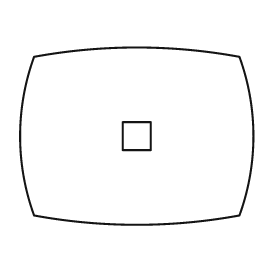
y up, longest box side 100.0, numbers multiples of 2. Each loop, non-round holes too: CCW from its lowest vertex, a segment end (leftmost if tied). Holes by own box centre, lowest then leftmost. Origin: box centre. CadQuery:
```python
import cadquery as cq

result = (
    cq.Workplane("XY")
    .moveTo(-44.0, -34.0)
    .threePointArc((0.0, -38.0), (44.0, -34.0))
    .threePointArc((50.0, 0.0), (44.0, 34.0))
    .threePointArc((0.0, 38.0), (-44.0, 34.0))
    .threePointArc((-50.0, 0.0), (-44.0, -34.0))
    .close()
    .moveTo(-6.0, -6.0)
    .lineTo(6.0, -6.0)
    .lineTo(6.0, 6.0)
    .lineTo(-6.0, 6.0)
    .close()
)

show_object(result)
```